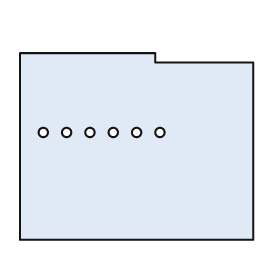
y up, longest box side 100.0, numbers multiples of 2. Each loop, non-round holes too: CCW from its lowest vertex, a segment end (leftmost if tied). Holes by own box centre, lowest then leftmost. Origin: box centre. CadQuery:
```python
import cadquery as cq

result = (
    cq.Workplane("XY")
    .moveTo(-50.0, -40.0)
    .lineTo(50.0, -40.0)
    .lineTo(50.0, 36.0)
    .lineTo(8.0, 36.0)
    .lineTo(8.0, 40.0)
    .lineTo(-50.0, 40.0)
    .close()
    .moveTo(-40.0, 6.0)
    .circle(2.0)
    .moveTo(-30.0, 6.0)
    .circle(2.0)
    .moveTo(-20.0, 6.0)
    .circle(2.0)
    .moveTo(-10.0, 6.0)
    .circle(2.0)
    .moveTo(0.0, 6.0)
    .circle(2.0)
    .moveTo(10.0, 6.0)
    .circle(2.0)
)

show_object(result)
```